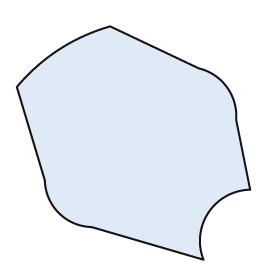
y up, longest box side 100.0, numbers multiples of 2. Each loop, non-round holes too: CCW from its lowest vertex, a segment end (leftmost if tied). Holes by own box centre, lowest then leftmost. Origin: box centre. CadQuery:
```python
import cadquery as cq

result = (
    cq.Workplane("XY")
    .moveTo(30.0, -50.0)
    .threePointArc((32.0, -30.0), (50.0, -20.0))
    .lineTo(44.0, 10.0)
    .threePointArc((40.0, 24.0), (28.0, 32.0))
    .lineTo(-10.0, 50.0)
    .threePointArc((-32.0, 40.0), (-50.0, 24.0))
    .lineTo(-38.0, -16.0)
    .threePointArc((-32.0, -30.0), (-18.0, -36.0))
    .close()
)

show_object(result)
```